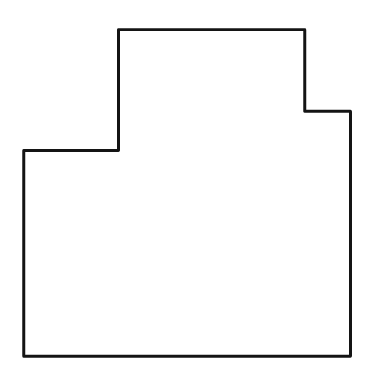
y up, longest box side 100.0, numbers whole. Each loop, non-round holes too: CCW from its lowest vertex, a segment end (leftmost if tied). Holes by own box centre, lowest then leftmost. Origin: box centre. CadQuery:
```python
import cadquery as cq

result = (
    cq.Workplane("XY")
    .moveTo(-50.0, -50.0)
    .lineTo(50.0, -50.0)
    .lineTo(50.0, 25.0)
    .lineTo(36.0, 25.0)
    .lineTo(36.0, 50.0)
    .lineTo(-21.0, 50.0)
    .lineTo(-21.0, 13.0)
    .lineTo(-50.0, 13.0)
    .close()
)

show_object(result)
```